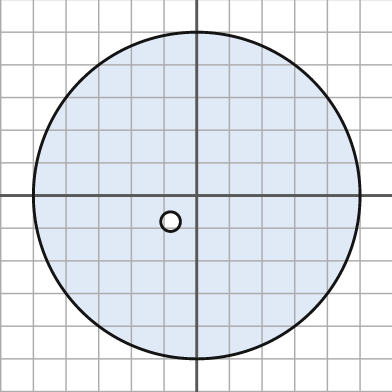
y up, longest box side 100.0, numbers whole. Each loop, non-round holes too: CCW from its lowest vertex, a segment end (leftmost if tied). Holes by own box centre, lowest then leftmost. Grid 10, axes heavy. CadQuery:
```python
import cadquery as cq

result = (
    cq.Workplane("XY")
    .moveTo(0.0, 0.0)
    .circle(50.0)
    .moveTo(-8.0, -8.0)
    .circle(3.0)
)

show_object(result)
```